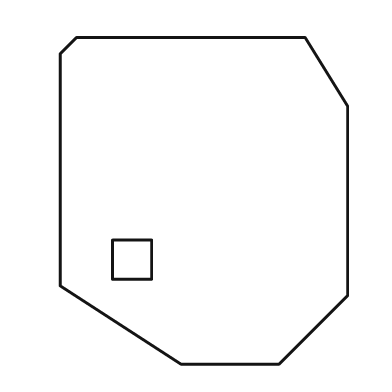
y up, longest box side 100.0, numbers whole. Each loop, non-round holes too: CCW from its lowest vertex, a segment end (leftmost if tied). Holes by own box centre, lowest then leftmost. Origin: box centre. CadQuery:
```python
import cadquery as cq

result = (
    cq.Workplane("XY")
    .moveTo(-7.0, -50.0)
    .lineTo(23.0, -50.0)
    .lineTo(44.0, -29.0)
    .lineTo(44.0, 29.0)
    .lineTo(31.0, 50.0)
    .lineTo(-39.0, 50.0)
    .lineTo(-44.0, 45.0)
    .lineTo(-44.0, -26.0)
    .close()
    .moveTo(-28.0, -24.0)
    .lineTo(-16.0, -24.0)
    .lineTo(-16.0, -12.0)
    .lineTo(-28.0, -12.0)
    .close()
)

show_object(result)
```